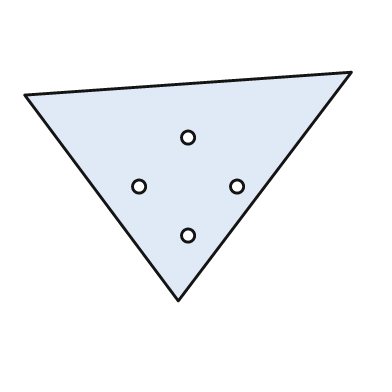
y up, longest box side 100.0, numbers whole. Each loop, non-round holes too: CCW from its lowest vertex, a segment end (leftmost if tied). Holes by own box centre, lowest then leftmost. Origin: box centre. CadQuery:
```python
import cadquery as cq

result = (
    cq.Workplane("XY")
    .moveTo(-3.0, -35.0)
    .lineTo(50.0, 35.0)
    .lineTo(-50.0, 28.0)
    .close()
    .moveTo(0.0, -15.0)
    .circle(2.0)
    .moveTo(-15.0, 0.0)
    .circle(2.0)
    .moveTo(15.0, 0.0)
    .circle(2.0)
    .moveTo(0.0, 15.0)
    .circle(2.0)
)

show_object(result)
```